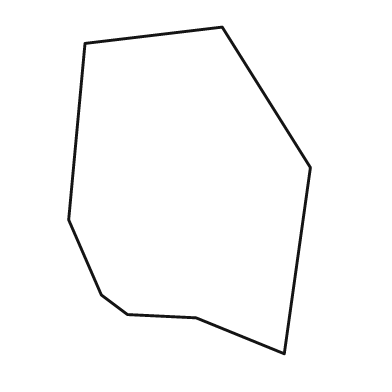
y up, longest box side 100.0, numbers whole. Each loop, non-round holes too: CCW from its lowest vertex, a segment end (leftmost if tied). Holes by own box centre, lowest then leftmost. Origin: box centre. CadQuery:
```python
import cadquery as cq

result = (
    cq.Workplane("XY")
    .moveTo(29.0, -50.0)
    .lineTo(37.0, 7.0)
    .lineTo(10.0, 50.0)
    .lineTo(-32.0, 45.0)
    .lineTo(-37.0, -9.0)
    .lineTo(-27.0, -32.0)
    .lineTo(-19.0, -38.0)
    .lineTo(2.0, -39.0)
    .close()
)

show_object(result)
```